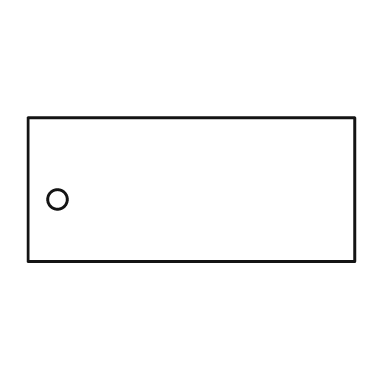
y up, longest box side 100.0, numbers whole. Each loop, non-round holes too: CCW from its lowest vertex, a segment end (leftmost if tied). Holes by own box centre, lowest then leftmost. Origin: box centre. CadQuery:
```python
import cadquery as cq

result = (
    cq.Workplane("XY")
    .moveTo(-50.0, -22.0)
    .lineTo(50.0, -22.0)
    .lineTo(50.0, 22.0)
    .lineTo(-50.0, 22.0)
    .close()
    .moveTo(-41.0, -3.0)
    .circle(3.0)
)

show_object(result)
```